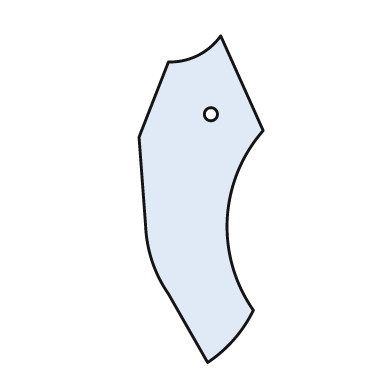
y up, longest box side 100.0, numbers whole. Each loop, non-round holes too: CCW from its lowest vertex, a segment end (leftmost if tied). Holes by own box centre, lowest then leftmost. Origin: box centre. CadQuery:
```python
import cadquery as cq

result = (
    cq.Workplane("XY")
    .moveTo(2.0, -50.0)
    .threePointArc((10.0, -43.0), (16.0, -34.0))
    .threePointArc((8.0, -6.0), (19.0, 21.0))
    .lineTo(6.0, 50.0)
    .threePointArc((-1.0, 44.0), (-10.0, 42.0))
    .lineTo(-19.0, 19.0)
    .lineTo(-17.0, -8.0)
    .threePointArc((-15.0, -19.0), (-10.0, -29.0))
    .close()
    .moveTo(3.0, 26.0)
    .circle(2.0)
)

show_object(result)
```